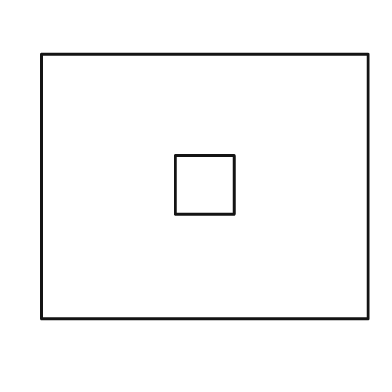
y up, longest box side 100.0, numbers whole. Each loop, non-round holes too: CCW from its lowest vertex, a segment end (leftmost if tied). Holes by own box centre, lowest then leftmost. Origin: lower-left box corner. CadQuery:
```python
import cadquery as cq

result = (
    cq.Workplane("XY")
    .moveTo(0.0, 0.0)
    .lineTo(100.0, 0.0)
    .lineTo(100.0, 81.0)
    .lineTo(0.0, 81.0)
    .close()
    .moveTo(41.0, 32.0)
    .lineTo(59.0, 32.0)
    .lineTo(59.0, 50.0)
    .lineTo(41.0, 50.0)
    .close()
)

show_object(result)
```